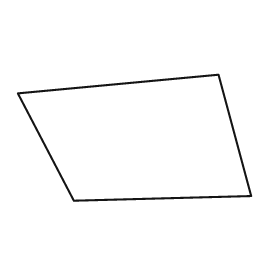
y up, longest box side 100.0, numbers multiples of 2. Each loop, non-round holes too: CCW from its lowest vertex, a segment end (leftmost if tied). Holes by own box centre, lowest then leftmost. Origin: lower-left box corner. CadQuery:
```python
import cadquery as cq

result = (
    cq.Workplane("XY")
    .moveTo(24.0, 0.0)
    .lineTo(100.0, 2.0)
    .lineTo(86.0, 54.0)
    .lineTo(0.0, 46.0)
    .close()
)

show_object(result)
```